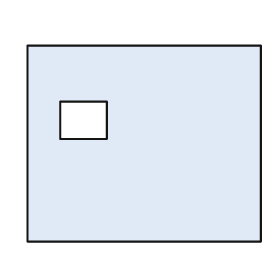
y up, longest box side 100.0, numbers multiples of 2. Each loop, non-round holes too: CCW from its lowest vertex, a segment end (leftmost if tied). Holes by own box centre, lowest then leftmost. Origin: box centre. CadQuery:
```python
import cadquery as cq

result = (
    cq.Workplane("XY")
    .moveTo(-50.0, -42.0)
    .lineTo(50.0, -42.0)
    .lineTo(50.0, 42.0)
    .lineTo(-50.0, 42.0)
    .close()
    .moveTo(-36.0, 2.0)
    .lineTo(-16.0, 2.0)
    .lineTo(-16.0, 18.0)
    .lineTo(-36.0, 18.0)
    .close()
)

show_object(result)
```